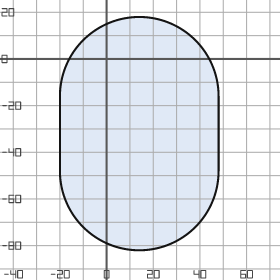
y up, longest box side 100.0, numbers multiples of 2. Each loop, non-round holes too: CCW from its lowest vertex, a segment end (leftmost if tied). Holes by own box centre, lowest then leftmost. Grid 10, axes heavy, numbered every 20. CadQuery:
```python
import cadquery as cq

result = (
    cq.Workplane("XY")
    .moveTo(-20.0, -48.0)
    .threePointArc((14.0, -82.0), (48.0, -48.0))
    .lineTo(48.0, -16.0)
    .threePointArc((14.0, 18.0), (-20.0, -16.0))
    .close()
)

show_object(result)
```